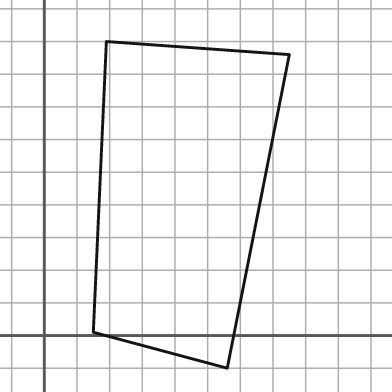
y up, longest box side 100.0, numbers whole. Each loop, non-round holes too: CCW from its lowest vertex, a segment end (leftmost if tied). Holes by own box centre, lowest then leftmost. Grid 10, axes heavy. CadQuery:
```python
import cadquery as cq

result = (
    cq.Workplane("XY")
    .moveTo(56.0, -10.0)
    .lineTo(75.0, 86.0)
    .lineTo(19.0, 90.0)
    .lineTo(15.0, 1.0)
    .close()
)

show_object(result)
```